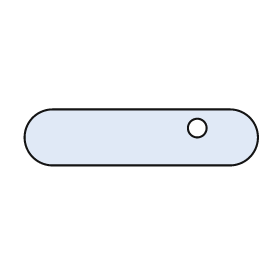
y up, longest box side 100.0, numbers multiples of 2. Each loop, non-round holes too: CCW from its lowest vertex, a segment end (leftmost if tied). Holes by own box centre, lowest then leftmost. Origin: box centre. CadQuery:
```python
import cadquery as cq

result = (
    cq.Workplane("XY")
    .moveTo(-38.0, -12.0)
    .lineTo(38.0, -12.0)
    .threePointArc((50.0, 0.0), (38.0, 12.0))
    .lineTo(-38.0, 12.0)
    .threePointArc((-50.0, 0.0), (-38.0, -12.0))
    .close()
    .moveTo(24.0, 4.0)
    .circle(4.0)
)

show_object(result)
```